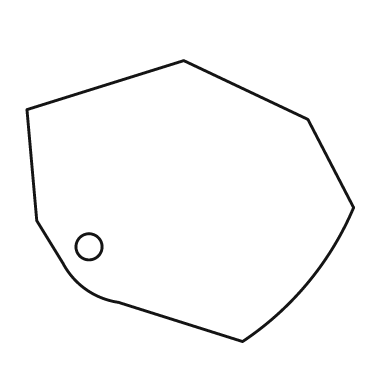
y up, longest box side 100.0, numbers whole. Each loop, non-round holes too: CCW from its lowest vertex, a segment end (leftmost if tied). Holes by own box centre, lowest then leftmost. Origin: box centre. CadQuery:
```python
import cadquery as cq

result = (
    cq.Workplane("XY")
    .moveTo(16.0, -43.0)
    .threePointArc((36.0, -25.0), (50.0, -2.0))
    .lineTo(36.0, 25.0)
    .lineTo(-2.0, 43.0)
    .lineTo(-50.0, 28.0)
    .lineTo(-47.0, -6.0)
    .lineTo(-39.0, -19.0)
    .threePointArc((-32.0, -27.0), (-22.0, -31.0))
    .close()
    .moveTo(-31.0, -14.0)
    .circle(4.0)
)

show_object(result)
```